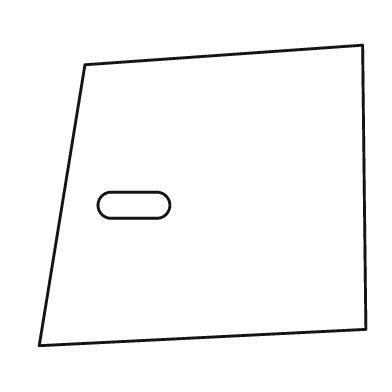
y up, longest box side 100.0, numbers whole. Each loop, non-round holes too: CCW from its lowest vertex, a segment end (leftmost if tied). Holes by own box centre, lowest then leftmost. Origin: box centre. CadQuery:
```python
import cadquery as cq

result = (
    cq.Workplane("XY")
    .moveTo(-50.0, -46.0)
    .lineTo(50.0, -41.0)
    .lineTo(49.0, 46.0)
    .lineTo(-36.0, 40.0)
    .close()
    .moveTo(-28.0, -7.0)
    .lineTo(-14.0, -7.0)
    .threePointArc((-10.0, -3.0), (-14.0, 1.0))
    .lineTo(-28.0, 1.0)
    .threePointArc((-32.0, -3.0), (-28.0, -7.0))
    .close()
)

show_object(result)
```